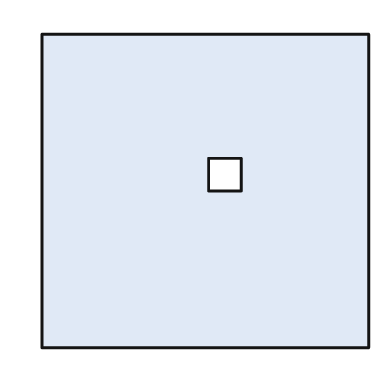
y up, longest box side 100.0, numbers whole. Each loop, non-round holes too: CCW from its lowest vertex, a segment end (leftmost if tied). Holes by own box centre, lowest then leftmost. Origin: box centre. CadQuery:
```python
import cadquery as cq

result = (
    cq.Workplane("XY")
    .moveTo(-50.0, -48.0)
    .lineTo(50.0, -48.0)
    .lineTo(50.0, 48.0)
    .lineTo(-50.0, 48.0)
    .close()
    .moveTo(1.0, 0.0)
    .lineTo(11.0, 0.0)
    .lineTo(11.0, 10.0)
    .lineTo(1.0, 10.0)
    .close()
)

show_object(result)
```